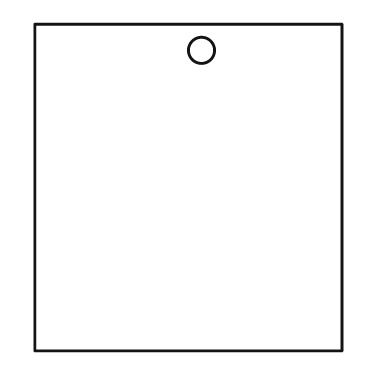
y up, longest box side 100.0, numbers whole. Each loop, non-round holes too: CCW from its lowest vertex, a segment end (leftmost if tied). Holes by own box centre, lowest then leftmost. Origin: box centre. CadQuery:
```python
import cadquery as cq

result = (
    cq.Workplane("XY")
    .moveTo(-47.0, -50.0)
    .lineTo(47.0, -50.0)
    .lineTo(47.0, 50.0)
    .lineTo(-47.0, 50.0)
    .close()
    .moveTo(4.0, 42.0)
    .circle(4.0)
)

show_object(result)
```